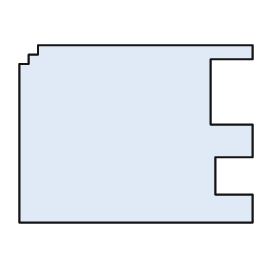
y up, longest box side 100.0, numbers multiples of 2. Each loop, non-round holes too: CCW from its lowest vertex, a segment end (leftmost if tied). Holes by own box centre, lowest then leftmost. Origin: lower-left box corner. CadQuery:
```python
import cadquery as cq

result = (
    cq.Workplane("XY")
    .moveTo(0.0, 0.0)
    .lineTo(100.0, 0.0)
    .lineTo(100.0, 12.0)
    .lineTo(84.0, 12.0)
    .lineTo(84.0, 28.0)
    .lineTo(100.0, 28.0)
    .lineTo(100.0, 42.0)
    .lineTo(82.0, 42.0)
    .lineTo(82.0, 70.0)
    .lineTo(100.0, 70.0)
    .lineTo(100.0, 76.0)
    .lineTo(8.0, 76.0)
    .lineTo(8.0, 72.0)
    .lineTo(4.0, 72.0)
    .lineTo(4.0, 68.0)
    .lineTo(0.0, 68.0)
    .close()
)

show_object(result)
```